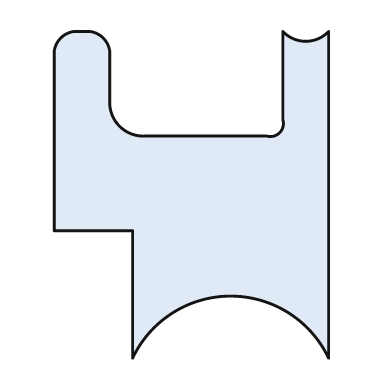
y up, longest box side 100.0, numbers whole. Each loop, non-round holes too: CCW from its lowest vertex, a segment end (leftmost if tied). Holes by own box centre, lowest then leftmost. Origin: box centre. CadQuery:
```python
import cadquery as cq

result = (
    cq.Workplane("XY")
    .moveTo(-18.0, -50.0)
    .threePointArc((12.0, -31.0), (42.0, -50.0))
    .lineTo(42.0, 50.0)
    .threePointArc((35.0, 47.0), (28.0, 50.0))
    .lineTo(28.0, 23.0)
    .threePointArc((27.0, 19.0), (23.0, 18.0))
    .lineTo(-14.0, 18.0)
    .threePointArc((-22.0, 21.0), (-25.0, 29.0))
    .lineTo(-25.0, 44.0)
    .threePointArc((-27.0, 48.0), (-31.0, 50.0))
    .lineTo(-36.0, 50.0)
    .threePointArc((-40.0, 48.0), (-42.0, 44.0))
    .lineTo(-42.0, -11.0)
    .lineTo(-18.0, -11.0)
    .close()
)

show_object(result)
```